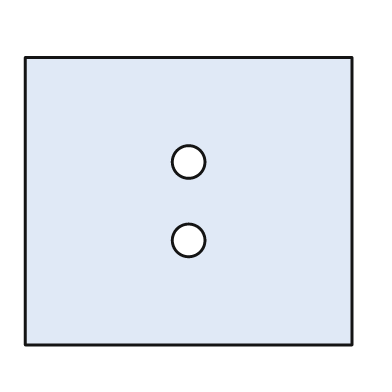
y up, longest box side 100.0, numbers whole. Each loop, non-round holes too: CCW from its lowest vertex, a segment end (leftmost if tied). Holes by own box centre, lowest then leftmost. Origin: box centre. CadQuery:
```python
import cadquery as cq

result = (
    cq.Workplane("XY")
    .moveTo(-50.0, -44.0)
    .lineTo(50.0, -44.0)
    .lineTo(50.0, 44.0)
    .lineTo(-50.0, 44.0)
    .close()
    .moveTo(0.0, -12.0)
    .circle(5.0)
    .moveTo(0.0, 12.0)
    .circle(5.0)
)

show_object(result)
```